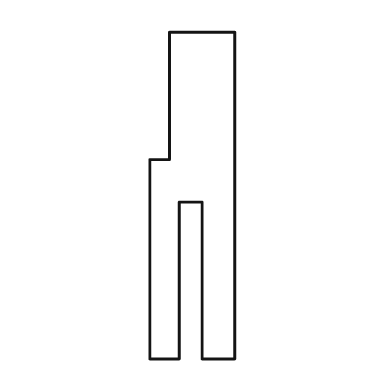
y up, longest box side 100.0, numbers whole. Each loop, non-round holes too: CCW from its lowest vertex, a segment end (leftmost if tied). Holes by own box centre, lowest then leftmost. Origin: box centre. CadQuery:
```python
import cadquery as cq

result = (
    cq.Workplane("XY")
    .moveTo(-13.0, -50.0)
    .lineTo(-4.0, -50.0)
    .lineTo(-4.0, -2.0)
    .lineTo(3.0, -2.0)
    .lineTo(3.0, -50.0)
    .lineTo(13.0, -50.0)
    .lineTo(13.0, 50.0)
    .lineTo(-7.0, 50.0)
    .lineTo(-7.0, 11.0)
    .lineTo(-13.0, 11.0)
    .close()
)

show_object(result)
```